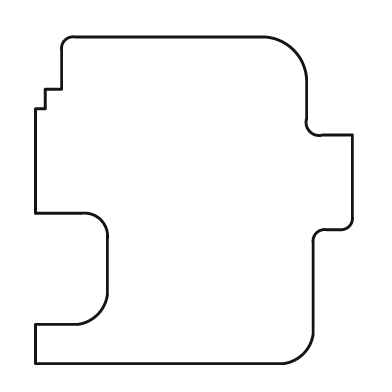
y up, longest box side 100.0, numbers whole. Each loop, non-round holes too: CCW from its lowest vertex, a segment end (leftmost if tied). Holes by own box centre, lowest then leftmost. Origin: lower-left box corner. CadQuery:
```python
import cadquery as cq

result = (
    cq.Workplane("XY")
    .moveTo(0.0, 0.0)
    .lineTo(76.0, 0.0)
    .threePointArc((82.0, 3.0), (85.0, 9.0))
    .lineTo(85.0, 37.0)
    .threePointArc((86.0, 40.0), (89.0, 41.0))
    .lineTo(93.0, 41.0)
    .threePointArc((96.0, 42.0), (97.0, 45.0))
    .lineTo(97.0, 70.0)
    .lineTo(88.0, 70.0)
    .threePointArc((84.0, 71.0), (83.0, 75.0))
    .lineTo(83.0, 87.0)
    .threePointArc((79.0, 96.0), (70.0, 100.0))
    .lineTo(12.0, 100.0)
    .threePointArc((9.0, 99.0), (8.0, 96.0))
    .lineTo(8.0, 84.0)
    .lineTo(3.0, 84.0)
    .lineTo(3.0, 78.0)
    .lineTo(0.0, 78.0)
    .lineTo(0.0, 46.0)
    .lineTo(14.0, 46.0)
    .threePointArc((20.0, 44.0), (22.0, 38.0))
    .lineTo(22.0, 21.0)
    .threePointArc((19.0, 15.0), (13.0, 12.0))
    .lineTo(0.0, 12.0)
    .close()
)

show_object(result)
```